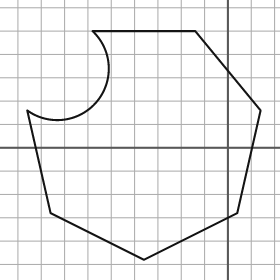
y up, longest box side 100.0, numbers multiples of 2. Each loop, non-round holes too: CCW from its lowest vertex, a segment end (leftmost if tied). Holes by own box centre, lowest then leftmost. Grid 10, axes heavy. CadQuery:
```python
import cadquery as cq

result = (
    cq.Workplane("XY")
    .moveTo(-36.0, -48.0)
    .lineTo(4.0, -28.0)
    .lineTo(14.0, 16.0)
    .lineTo(-14.0, 50.0)
    .lineTo(-58.0, 50.0)
    .threePointArc((-56.0, 20.0), (-86.0, 16.0))
    .lineTo(-76.0, -28.0)
    .close()
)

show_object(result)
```